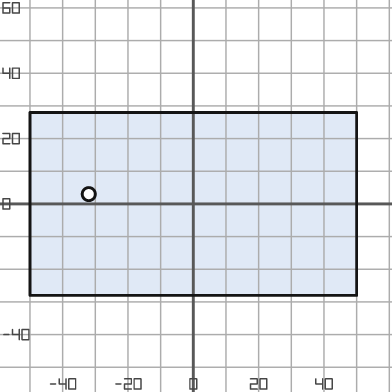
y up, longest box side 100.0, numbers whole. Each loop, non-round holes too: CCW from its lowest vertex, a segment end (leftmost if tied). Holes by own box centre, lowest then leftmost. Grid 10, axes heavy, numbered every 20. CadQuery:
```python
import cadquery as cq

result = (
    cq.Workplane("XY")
    .moveTo(-50.0, -28.0)
    .lineTo(50.0, -28.0)
    .lineTo(50.0, 28.0)
    .lineTo(-50.0, 28.0)
    .close()
    .moveTo(-32.0, 3.0)
    .circle(2.0)
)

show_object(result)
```